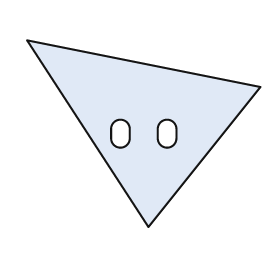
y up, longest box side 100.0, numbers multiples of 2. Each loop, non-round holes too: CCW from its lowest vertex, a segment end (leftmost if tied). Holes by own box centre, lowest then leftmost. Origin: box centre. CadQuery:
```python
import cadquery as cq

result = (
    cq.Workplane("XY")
    .moveTo(2.0, -40.0)
    .lineTo(50.0, 20.0)
    .lineTo(-50.0, 40.0)
    .close()
    .moveTo(-14.0, -2.0)
    .threePointArc((-10.0, -6.0), (-6.0, -2.0))
    .lineTo(-6.0, 2.0)
    .threePointArc((-10.0, 6.0), (-14.0, 2.0))
    .close()
    .moveTo(6.0, -2.0)
    .threePointArc((10.0, -6.0), (14.0, -2.0))
    .lineTo(14.0, 2.0)
    .threePointArc((10.0, 6.0), (6.0, 2.0))
    .close()
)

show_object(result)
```